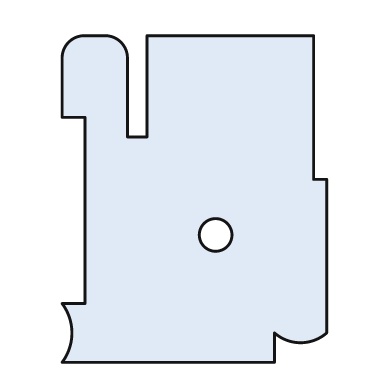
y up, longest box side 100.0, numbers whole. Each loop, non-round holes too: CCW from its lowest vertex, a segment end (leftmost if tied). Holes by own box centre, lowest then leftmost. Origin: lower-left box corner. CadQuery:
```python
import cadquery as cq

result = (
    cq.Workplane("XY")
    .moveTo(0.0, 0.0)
    .lineTo(65.0, 0.0)
    .lineTo(65.0, 9.0)
    .threePointArc((73.0, 6.0), (81.0, 9.0))
    .lineTo(81.0, 56.0)
    .lineTo(77.0, 56.0)
    .lineTo(77.0, 100.0)
    .lineTo(26.0, 100.0)
    .lineTo(26.0, 69.0)
    .lineTo(20.0, 69.0)
    .lineTo(20.0, 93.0)
    .threePointArc((18.0, 98.0), (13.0, 100.0))
    .lineTo(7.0, 100.0)
    .threePointArc((2.0, 98.0), (0.0, 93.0))
    .lineTo(0.0, 75.0)
    .lineTo(7.0, 75.0)
    .lineTo(7.0, 18.0)
    .lineTo(0.0, 18.0)
    .threePointArc((3.0, 9.0), (0.0, 0.0))
    .close()
    .moveTo(47.0, 39.0)
    .circle(5.0)
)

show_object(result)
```